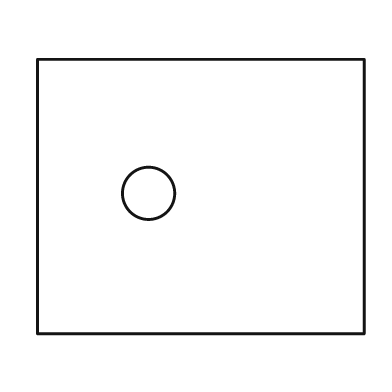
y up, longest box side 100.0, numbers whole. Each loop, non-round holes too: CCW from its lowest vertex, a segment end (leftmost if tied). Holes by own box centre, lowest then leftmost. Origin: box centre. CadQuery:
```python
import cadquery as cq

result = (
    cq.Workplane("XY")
    .moveTo(-50.0, -42.0)
    .lineTo(50.0, -42.0)
    .lineTo(50.0, 42.0)
    .lineTo(-50.0, 42.0)
    .close()
    .moveTo(-16.0, 1.0)
    .circle(8.0)
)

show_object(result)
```